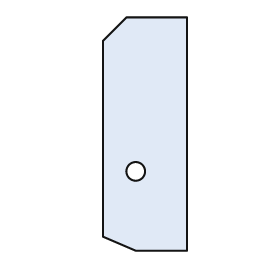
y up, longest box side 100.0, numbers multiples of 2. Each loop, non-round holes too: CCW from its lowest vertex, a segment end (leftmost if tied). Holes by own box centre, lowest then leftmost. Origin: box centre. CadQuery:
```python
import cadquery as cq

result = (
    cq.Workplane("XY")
    .moveTo(-4.0, -50.0)
    .lineTo(18.0, -50.0)
    .lineTo(18.0, 50.0)
    .lineTo(-8.0, 50.0)
    .lineTo(-18.0, 40.0)
    .lineTo(-18.0, -44.0)
    .close()
    .moveTo(-4.0, -16.0)
    .circle(4.0)
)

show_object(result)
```